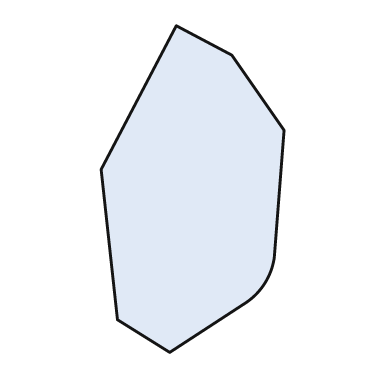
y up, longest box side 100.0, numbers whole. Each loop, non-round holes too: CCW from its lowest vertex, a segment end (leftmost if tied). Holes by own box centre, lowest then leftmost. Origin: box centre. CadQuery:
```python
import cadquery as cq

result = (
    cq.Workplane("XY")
    .moveTo(-7.0, -50.0)
    .lineTo(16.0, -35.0)
    .threePointArc((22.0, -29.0), (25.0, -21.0))
    .lineTo(28.0, 18.0)
    .lineTo(12.0, 41.0)
    .lineTo(-5.0, 50.0)
    .lineTo(-28.0, 6.0)
    .lineTo(-23.0, -40.0)
    .close()
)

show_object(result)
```